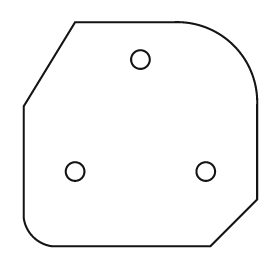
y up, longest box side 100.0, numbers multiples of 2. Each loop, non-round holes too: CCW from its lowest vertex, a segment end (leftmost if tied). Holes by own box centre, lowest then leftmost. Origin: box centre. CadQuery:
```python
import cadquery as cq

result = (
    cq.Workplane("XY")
    .moveTo(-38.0, -48.0)
    .lineTo(30.0, -48.0)
    .lineTo(50.0, -28.0)
    .lineTo(50.0, 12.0)
    .threePointArc((40.0, 38.0), (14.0, 48.0))
    .lineTo(-28.0, 48.0)
    .lineTo(-50.0, 12.0)
    .lineTo(-50.0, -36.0)
    .threePointArc((-46.0, -44.0), (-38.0, -48.0))
    .close()
    .moveTo(-28.0, -16.0)
    .circle(4.0)
    .moveTo(28.0, -16.0)
    .circle(4.0)
    .moveTo(0.0, 32.0)
    .circle(4.0)
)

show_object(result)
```